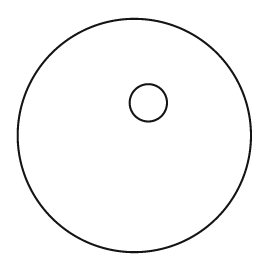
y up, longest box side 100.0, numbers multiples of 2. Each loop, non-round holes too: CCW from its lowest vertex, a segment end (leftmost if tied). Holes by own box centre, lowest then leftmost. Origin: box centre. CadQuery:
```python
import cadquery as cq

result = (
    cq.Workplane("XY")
    .moveTo(0.0, 0.0)
    .circle(50.0)
    .moveTo(6.0, 14.0)
    .circle(8.0)
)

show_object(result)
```